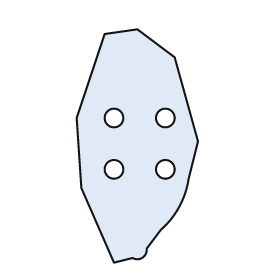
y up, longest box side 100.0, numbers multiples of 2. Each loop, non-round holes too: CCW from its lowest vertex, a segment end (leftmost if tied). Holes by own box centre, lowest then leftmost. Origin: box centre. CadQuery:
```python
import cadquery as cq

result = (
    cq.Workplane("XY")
    .moveTo(-10.0, -50.0)
    .lineTo(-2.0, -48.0)
    .threePointArc((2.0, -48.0), (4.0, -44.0))
    .lineTo(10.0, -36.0)
    .threePointArc((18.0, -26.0), (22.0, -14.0))
    .lineTo(26.0, 2.0)
    .lineTo(16.0, 38.0)
    .lineTo(0.0, 50.0)
    .lineTo(-14.0, 48.0)
    .lineTo(-26.0, 12.0)
    .lineTo(-24.0, -18.0)
    .close()
    .moveTo(-10.0, -10.0)
    .circle(4.0)
    .moveTo(12.0, -10.0)
    .circle(4.0)
    .moveTo(-10.0, 12.0)
    .circle(4.0)
    .moveTo(12.0, 12.0)
    .circle(4.0)
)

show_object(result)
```